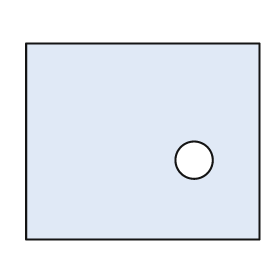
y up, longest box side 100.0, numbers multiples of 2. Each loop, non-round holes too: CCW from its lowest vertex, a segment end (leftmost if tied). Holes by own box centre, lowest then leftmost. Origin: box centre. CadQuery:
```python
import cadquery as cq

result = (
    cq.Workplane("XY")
    .moveTo(-50.0, -42.0)
    .lineTo(50.0, -42.0)
    .lineTo(50.0, 42.0)
    .lineTo(-50.0, 42.0)
    .close()
    .moveTo(22.0, -8.0)
    .circle(8.0)
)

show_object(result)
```